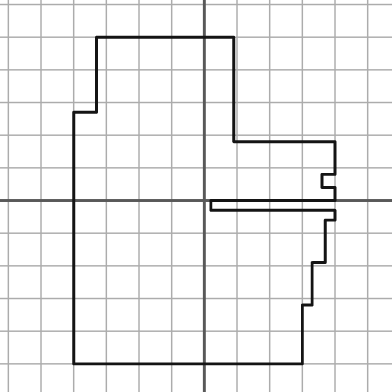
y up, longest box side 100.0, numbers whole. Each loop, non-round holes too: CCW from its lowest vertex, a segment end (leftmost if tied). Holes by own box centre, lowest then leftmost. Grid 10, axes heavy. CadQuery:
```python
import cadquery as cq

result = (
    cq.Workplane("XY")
    .moveTo(-40.0, -50.0)
    .lineTo(30.0, -50.0)
    .lineTo(30.0, -32.0)
    .lineTo(33.0, -32.0)
    .lineTo(33.0, -19.0)
    .lineTo(37.0, -19.0)
    .lineTo(37.0, -6.0)
    .lineTo(40.0, -6.0)
    .lineTo(40.0, -3.0)
    .lineTo(2.0, -3.0)
    .lineTo(2.0, 0.0)
    .lineTo(40.0, 0.0)
    .lineTo(40.0, 4.0)
    .lineTo(36.0, 4.0)
    .lineTo(36.0, 8.0)
    .lineTo(40.0, 8.0)
    .lineTo(40.0, 18.0)
    .lineTo(9.0, 18.0)
    .lineTo(9.0, 50.0)
    .lineTo(-33.0, 50.0)
    .lineTo(-33.0, 27.0)
    .lineTo(-40.0, 27.0)
    .close()
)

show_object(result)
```